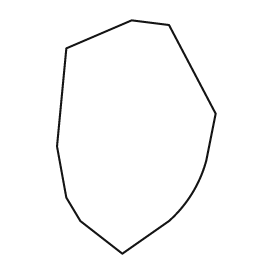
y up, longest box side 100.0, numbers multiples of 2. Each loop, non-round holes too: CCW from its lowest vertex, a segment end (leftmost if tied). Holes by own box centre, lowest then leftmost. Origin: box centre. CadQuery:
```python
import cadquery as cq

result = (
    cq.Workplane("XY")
    .moveTo(-6.0, -50.0)
    .lineTo(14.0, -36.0)
    .threePointArc((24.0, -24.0), (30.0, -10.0))
    .lineTo(34.0, 10.0)
    .lineTo(14.0, 48.0)
    .lineTo(-2.0, 50.0)
    .lineTo(-30.0, 38.0)
    .lineTo(-34.0, -4.0)
    .lineTo(-30.0, -26.0)
    .lineTo(-24.0, -36.0)
    .close()
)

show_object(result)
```